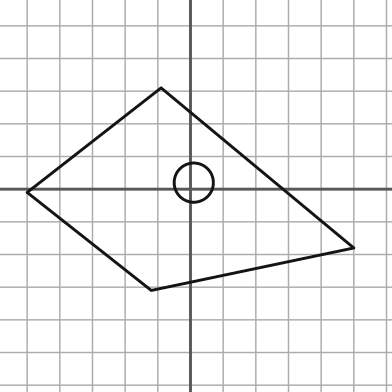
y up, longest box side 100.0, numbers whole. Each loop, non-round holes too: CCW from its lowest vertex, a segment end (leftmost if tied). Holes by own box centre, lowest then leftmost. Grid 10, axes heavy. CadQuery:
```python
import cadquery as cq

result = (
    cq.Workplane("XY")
    .moveTo(-12.0, -31.0)
    .lineTo(50.0, -18.0)
    .lineTo(-9.0, 31.0)
    .lineTo(-50.0, -1.0)
    .close()
    .moveTo(1.0, 2.0)
    .circle(6.0)
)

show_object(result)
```